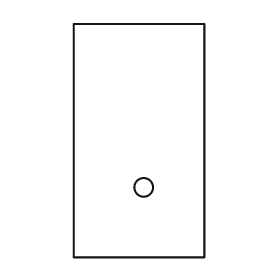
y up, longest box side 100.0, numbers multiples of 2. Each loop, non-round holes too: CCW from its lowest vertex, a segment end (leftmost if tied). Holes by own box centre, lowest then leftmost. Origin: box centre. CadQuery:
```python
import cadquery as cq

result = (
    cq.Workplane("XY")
    .moveTo(-28.0, -50.0)
    .lineTo(28.0, -50.0)
    .lineTo(28.0, 50.0)
    .lineTo(-28.0, 50.0)
    .close()
    .moveTo(2.0, -20.0)
    .circle(4.0)
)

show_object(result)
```